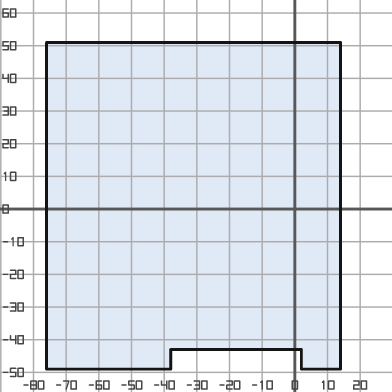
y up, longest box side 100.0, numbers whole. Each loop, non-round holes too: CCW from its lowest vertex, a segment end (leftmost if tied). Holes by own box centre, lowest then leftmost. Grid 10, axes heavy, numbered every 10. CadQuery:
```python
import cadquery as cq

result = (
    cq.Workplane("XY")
    .moveTo(-76.0, -49.0)
    .lineTo(-38.0, -49.0)
    .lineTo(-38.0, -43.0)
    .lineTo(2.0, -43.0)
    .lineTo(2.0, -49.0)
    .lineTo(14.0, -49.0)
    .lineTo(14.0, 51.0)
    .lineTo(-76.0, 51.0)
    .close()
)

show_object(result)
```